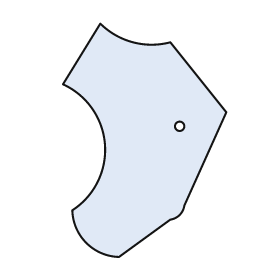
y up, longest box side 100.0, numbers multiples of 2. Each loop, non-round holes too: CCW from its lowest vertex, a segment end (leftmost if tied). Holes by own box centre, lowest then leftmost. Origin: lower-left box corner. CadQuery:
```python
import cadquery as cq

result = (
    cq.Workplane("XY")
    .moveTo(24.0, 0.0)
    .lineTo(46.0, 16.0)
    .threePointArc((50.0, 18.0), (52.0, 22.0))
    .lineTo(70.0, 62.0)
    .lineTo(46.0, 92.0)
    .threePointArc((30.0, 92.0), (16.0, 100.0))
    .lineTo(0.0, 74.0)
    .threePointArc((18.0, 48.0), (4.0, 20.0))
    .threePointArc((10.0, 6.0), (24.0, 0.0))
    .close()
    .moveTo(50.0, 56.0)
    .circle(2.0)
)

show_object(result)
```